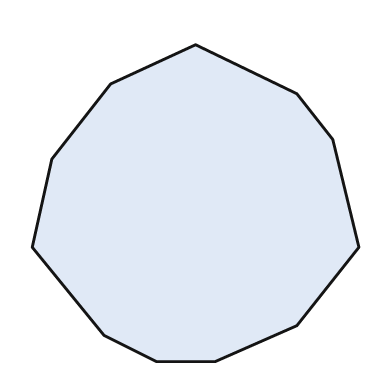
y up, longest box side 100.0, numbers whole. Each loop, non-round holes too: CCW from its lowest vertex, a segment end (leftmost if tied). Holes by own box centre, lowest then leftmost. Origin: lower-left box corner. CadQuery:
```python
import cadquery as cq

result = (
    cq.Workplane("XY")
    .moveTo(38.0, 0.0)
    .lineTo(56.0, 0.0)
    .lineTo(81.0, 11.0)
    .lineTo(100.0, 35.0)
    .lineTo(92.0, 68.0)
    .lineTo(81.0, 82.0)
    .lineTo(50.0, 97.0)
    .lineTo(24.0, 85.0)
    .lineTo(6.0, 62.0)
    .lineTo(0.0, 35.0)
    .lineTo(22.0, 8.0)
    .close()
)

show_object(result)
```